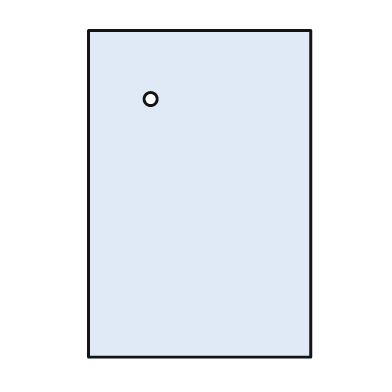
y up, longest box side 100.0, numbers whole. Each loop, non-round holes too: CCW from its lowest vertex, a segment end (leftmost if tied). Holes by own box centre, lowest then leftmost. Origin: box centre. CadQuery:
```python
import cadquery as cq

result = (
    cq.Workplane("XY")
    .moveTo(-34.0, -50.0)
    .lineTo(34.0, -50.0)
    .lineTo(34.0, 50.0)
    .lineTo(-34.0, 50.0)
    .close()
    .moveTo(-15.0, 29.0)
    .circle(2.0)
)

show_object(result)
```